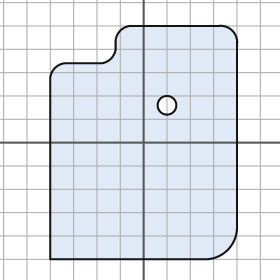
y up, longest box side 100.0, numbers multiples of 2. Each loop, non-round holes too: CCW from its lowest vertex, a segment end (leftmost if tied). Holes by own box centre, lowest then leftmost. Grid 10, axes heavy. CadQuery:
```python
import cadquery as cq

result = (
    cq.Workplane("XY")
    .moveTo(-40.0, -50.0)
    .lineTo(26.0, -50.0)
    .threePointArc((36.0, -46.0), (40.0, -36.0))
    .lineTo(40.0, 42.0)
    .threePointArc((38.0, 48.0), (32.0, 50.0))
    .lineTo(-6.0, 50.0)
    .threePointArc((-10.0, 48.0), (-12.0, 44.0))
    .lineTo(-12.0, 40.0)
    .threePointArc((-14.0, 36.0), (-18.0, 34.0))
    .lineTo(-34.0, 34.0)
    .threePointArc((-38.0, 32.0), (-40.0, 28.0))
    .close()
    .moveTo(10.0, 16.0)
    .circle(4.0)
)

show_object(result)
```